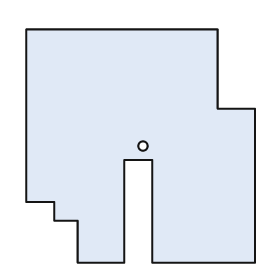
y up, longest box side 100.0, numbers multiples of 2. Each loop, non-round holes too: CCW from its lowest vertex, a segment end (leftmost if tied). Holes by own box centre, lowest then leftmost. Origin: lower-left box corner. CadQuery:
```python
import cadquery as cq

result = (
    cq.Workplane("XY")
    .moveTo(22.0, 0.0)
    .lineTo(42.0, 0.0)
    .lineTo(42.0, 44.0)
    .lineTo(54.0, 44.0)
    .lineTo(54.0, 0.0)
    .lineTo(98.0, 0.0)
    .lineTo(98.0, 66.0)
    .lineTo(82.0, 66.0)
    .lineTo(82.0, 100.0)
    .lineTo(0.0, 100.0)
    .lineTo(0.0, 26.0)
    .lineTo(12.0, 26.0)
    .lineTo(12.0, 18.0)
    .lineTo(22.0, 18.0)
    .close()
    .moveTo(50.0, 50.0)
    .circle(2.0)
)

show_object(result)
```